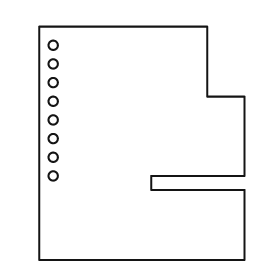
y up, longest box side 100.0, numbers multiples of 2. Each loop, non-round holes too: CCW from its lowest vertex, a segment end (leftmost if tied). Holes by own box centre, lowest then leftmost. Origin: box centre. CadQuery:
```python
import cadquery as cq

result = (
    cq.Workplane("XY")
    .moveTo(-44.0, -50.0)
    .lineTo(44.0, -50.0)
    .lineTo(44.0, -20.0)
    .lineTo(4.0, -20.0)
    .lineTo(4.0, -14.0)
    .lineTo(44.0, -14.0)
    .lineTo(44.0, 20.0)
    .lineTo(28.0, 20.0)
    .lineTo(28.0, 50.0)
    .lineTo(-44.0, 50.0)
    .close()
    .moveTo(-38.0, -14.0)
    .circle(2.0)
    .moveTo(-38.0, -6.0)
    .circle(2.0)
    .moveTo(-38.0, 2.0)
    .circle(2.0)
    .moveTo(-38.0, 10.0)
    .circle(2.0)
    .moveTo(-38.0, 18.0)
    .circle(2.0)
    .moveTo(-38.0, 26.0)
    .circle(2.0)
    .moveTo(-38.0, 34.0)
    .circle(2.0)
    .moveTo(-38.0, 42.0)
    .circle(2.0)
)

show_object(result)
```